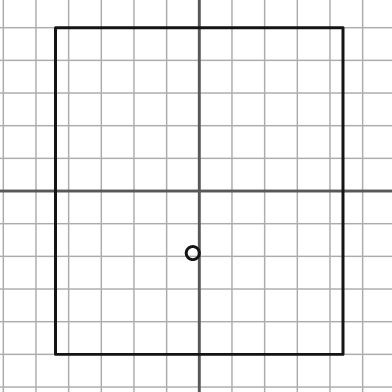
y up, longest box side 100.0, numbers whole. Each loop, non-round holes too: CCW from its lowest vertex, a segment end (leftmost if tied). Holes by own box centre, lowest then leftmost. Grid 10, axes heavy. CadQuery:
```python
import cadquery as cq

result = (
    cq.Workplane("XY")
    .moveTo(-44.0, -50.0)
    .lineTo(44.0, -50.0)
    .lineTo(44.0, 50.0)
    .lineTo(-44.0, 50.0)
    .close()
    .moveTo(-2.0, -19.0)
    .circle(2.0)
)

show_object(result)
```